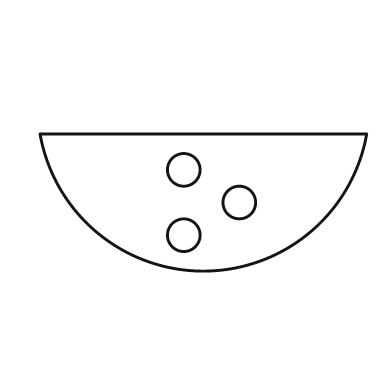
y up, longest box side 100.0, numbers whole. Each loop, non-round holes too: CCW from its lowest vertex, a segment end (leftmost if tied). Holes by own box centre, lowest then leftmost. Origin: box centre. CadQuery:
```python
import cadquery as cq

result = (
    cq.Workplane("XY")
    .moveTo(-50.0, 21.0)
    .threePointArc((0.0, -21.0), (50.0, 21.0))
    .close()
    .moveTo(-6.0, -10.0)
    .circle(5.0)
    .moveTo(11.0, 0.0)
    .circle(5.0)
    .moveTo(-6.0, 10.0)
    .circle(5.0)
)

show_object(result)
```